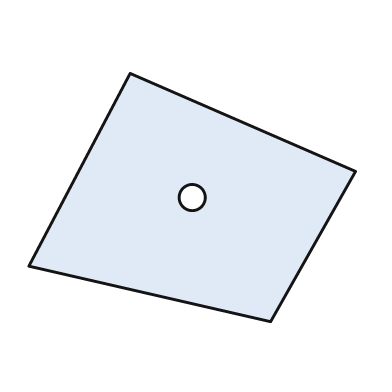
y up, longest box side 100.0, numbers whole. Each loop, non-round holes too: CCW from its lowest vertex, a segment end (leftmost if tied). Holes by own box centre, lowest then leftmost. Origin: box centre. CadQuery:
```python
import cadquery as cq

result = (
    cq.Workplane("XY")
    .moveTo(24.0, -38.0)
    .lineTo(50.0, 8.0)
    .lineTo(-19.0, 38.0)
    .lineTo(-50.0, -21.0)
    .close()
    .moveTo(0.0, 0.0)
    .circle(4.0)
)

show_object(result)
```